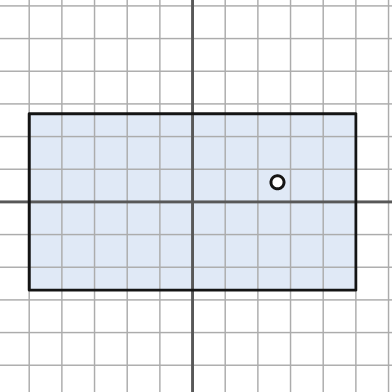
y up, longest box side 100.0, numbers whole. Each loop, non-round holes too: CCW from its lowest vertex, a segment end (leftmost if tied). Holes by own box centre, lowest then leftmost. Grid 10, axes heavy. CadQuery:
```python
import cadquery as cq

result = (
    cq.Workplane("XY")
    .moveTo(-50.0, -27.0)
    .lineTo(50.0, -27.0)
    .lineTo(50.0, 27.0)
    .lineTo(-50.0, 27.0)
    .close()
    .moveTo(26.0, 6.0)
    .circle(2.0)
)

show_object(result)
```